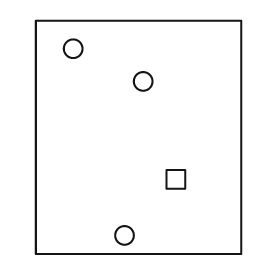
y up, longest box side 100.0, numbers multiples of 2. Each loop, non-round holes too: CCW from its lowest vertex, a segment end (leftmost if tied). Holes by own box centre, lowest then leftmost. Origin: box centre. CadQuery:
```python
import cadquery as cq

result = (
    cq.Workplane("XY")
    .moveTo(-44.0, -50.0)
    .lineTo(44.0, -50.0)
    .lineTo(44.0, 50.0)
    .lineTo(-44.0, 50.0)
    .close()
    .moveTo(-6.0, -42.0)
    .circle(4.0)
    .moveTo(12.0, -22.0)
    .lineTo(20.0, -22.0)
    .lineTo(20.0, -14.0)
    .lineTo(12.0, -14.0)
    .close()
    .moveTo(2.0, 24.0)
    .circle(4.0)
    .moveTo(-28.0, 38.0)
    .circle(4.0)
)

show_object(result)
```